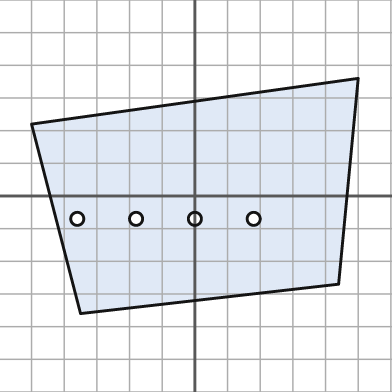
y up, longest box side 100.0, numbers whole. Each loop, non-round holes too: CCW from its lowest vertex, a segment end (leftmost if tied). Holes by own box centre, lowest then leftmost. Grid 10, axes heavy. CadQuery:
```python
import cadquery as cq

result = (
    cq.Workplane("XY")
    .moveTo(-35.0, -36.0)
    .lineTo(44.0, -27.0)
    .lineTo(50.0, 36.0)
    .lineTo(-50.0, 22.0)
    .close()
    .moveTo(-36.0, -7.0)
    .circle(2.0)
    .moveTo(-18.0, -7.0)
    .circle(2.0)
    .moveTo(0.0, -7.0)
    .circle(2.0)
    .moveTo(18.0, -7.0)
    .circle(2.0)
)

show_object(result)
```